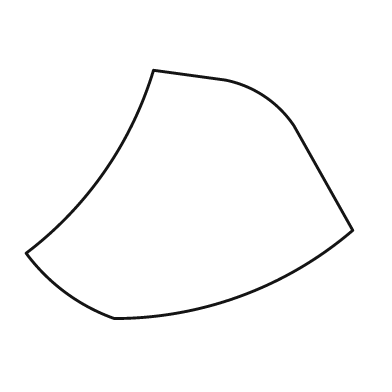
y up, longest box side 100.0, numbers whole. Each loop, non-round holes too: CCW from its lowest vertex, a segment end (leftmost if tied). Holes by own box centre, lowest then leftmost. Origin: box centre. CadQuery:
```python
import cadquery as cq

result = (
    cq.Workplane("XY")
    .moveTo(-23.0, -38.0)
    .threePointArc((16.0, -31.0), (50.0, -11.0))
    .lineTo(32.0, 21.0)
    .threePointArc((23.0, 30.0), (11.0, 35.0))
    .lineTo(-11.0, 38.0)
    .threePointArc((-26.0, 7.0), (-50.0, -18.0))
    .threePointArc((-38.0, -30.0), (-23.0, -38.0))
    .close()
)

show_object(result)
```